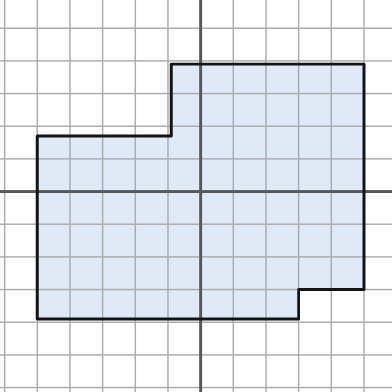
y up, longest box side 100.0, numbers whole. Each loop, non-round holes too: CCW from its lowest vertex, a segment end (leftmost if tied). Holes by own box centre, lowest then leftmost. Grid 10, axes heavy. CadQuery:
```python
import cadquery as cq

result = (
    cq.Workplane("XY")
    .moveTo(-50.0, -39.0)
    .lineTo(30.0, -39.0)
    .lineTo(30.0, -30.0)
    .lineTo(50.0, -30.0)
    .lineTo(50.0, 39.0)
    .lineTo(-9.0, 39.0)
    .lineTo(-9.0, 17.0)
    .lineTo(-50.0, 17.0)
    .close()
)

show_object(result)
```